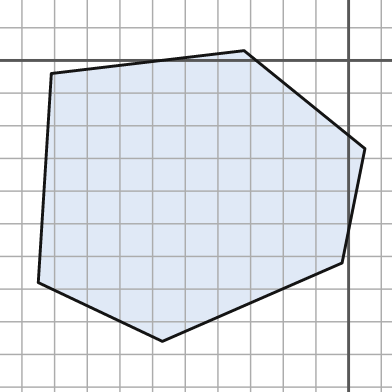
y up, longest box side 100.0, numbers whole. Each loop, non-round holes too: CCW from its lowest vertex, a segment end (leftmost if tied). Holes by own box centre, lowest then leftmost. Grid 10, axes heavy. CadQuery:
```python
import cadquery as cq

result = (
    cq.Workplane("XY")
    .moveTo(-57.0, -86.0)
    .lineTo(-2.0, -62.0)
    .lineTo(5.0, -27.0)
    .lineTo(-32.0, 3.0)
    .lineTo(-91.0, -4.0)
    .lineTo(-95.0, -68.0)
    .close()
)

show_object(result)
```